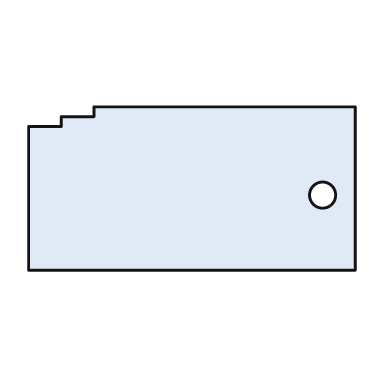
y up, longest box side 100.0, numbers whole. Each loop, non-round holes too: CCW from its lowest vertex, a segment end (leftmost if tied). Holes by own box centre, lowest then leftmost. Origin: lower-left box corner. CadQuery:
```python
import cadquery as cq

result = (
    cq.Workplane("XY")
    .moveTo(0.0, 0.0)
    .lineTo(100.0, 0.0)
    .lineTo(100.0, 50.0)
    .lineTo(20.0, 50.0)
    .lineTo(20.0, 47.0)
    .lineTo(10.0, 47.0)
    .lineTo(10.0, 44.0)
    .lineTo(0.0, 44.0)
    .close()
    .moveTo(90.0, 23.0)
    .circle(4.0)
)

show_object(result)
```